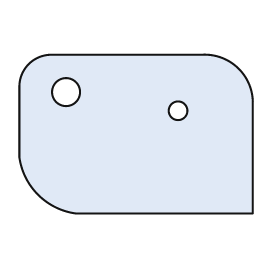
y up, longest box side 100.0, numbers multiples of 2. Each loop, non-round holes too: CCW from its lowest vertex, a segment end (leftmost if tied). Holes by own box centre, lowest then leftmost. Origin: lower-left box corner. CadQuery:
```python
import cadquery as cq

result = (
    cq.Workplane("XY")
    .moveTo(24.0, 0.0)
    .lineTo(100.0, 0.0)
    .lineTo(100.0, 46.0)
    .threePointArc((94.0, 62.0), (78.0, 68.0))
    .lineTo(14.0, 68.0)
    .threePointArc((4.0, 64.0), (0.0, 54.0))
    .lineTo(0.0, 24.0)
    .threePointArc((8.0, 8.0), (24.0, 0.0))
    .close()
    .moveTo(68.0, 44.0)
    .circle(4.0)
    .moveTo(20.0, 52.0)
    .circle(6.0)
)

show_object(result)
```